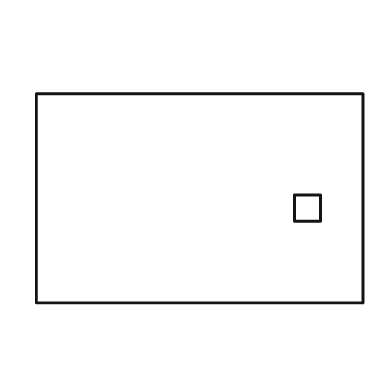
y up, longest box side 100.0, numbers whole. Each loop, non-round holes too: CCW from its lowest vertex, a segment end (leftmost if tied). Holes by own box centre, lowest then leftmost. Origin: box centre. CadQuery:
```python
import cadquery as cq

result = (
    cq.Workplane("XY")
    .moveTo(-50.0, -32.0)
    .lineTo(50.0, -32.0)
    .lineTo(50.0, 32.0)
    .lineTo(-50.0, 32.0)
    .close()
    .moveTo(29.0, -7.0)
    .lineTo(37.0, -7.0)
    .lineTo(37.0, 1.0)
    .lineTo(29.0, 1.0)
    .close()
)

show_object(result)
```